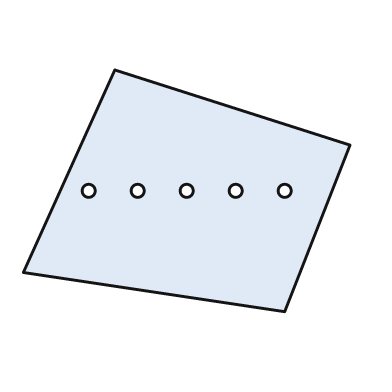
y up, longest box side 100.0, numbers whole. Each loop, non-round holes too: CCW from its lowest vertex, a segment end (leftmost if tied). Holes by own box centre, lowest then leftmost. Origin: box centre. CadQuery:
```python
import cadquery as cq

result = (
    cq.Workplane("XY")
    .moveTo(30.0, -37.0)
    .lineTo(50.0, 14.0)
    .lineTo(-22.0, 37.0)
    .lineTo(-50.0, -25.0)
    .close()
    .moveTo(-30.0, 0.0)
    .circle(2.0)
    .moveTo(-15.0, 0.0)
    .circle(2.0)
    .moveTo(0.0, 0.0)
    .circle(2.0)
    .moveTo(15.0, 0.0)
    .circle(2.0)
    .moveTo(30.0, 0.0)
    .circle(2.0)
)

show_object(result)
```